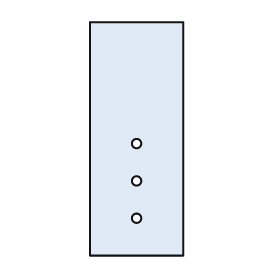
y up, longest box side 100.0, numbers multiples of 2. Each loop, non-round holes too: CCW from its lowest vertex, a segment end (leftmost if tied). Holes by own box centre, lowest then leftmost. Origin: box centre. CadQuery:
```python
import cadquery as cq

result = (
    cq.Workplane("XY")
    .moveTo(-20.0, -50.0)
    .lineTo(20.0, -50.0)
    .lineTo(20.0, 50.0)
    .lineTo(-20.0, 50.0)
    .close()
    .moveTo(0.0, -34.0)
    .circle(2.0)
    .moveTo(0.0, -18.0)
    .circle(2.0)
    .moveTo(0.0, -2.0)
    .circle(2.0)
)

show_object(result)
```